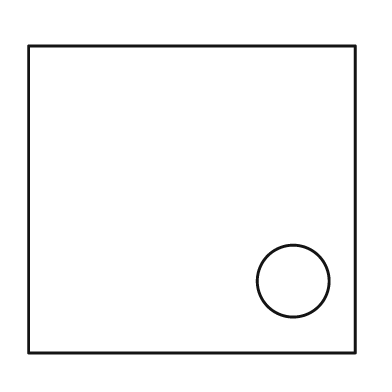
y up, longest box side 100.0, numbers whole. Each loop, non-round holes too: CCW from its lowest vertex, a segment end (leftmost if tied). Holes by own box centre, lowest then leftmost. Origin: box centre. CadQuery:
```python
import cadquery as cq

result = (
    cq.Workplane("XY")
    .moveTo(-50.0, -47.0)
    .lineTo(50.0, -47.0)
    .lineTo(50.0, 47.0)
    .lineTo(-50.0, 47.0)
    .close()
    .moveTo(31.0, -25.0)
    .circle(11.0)
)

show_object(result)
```